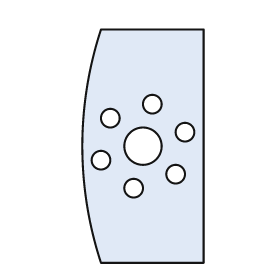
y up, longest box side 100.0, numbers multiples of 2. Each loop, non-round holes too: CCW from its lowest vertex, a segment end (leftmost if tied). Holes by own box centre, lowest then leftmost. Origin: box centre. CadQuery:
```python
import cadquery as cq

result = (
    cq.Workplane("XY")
    .moveTo(-18.0, -50.0)
    .lineTo(26.0, -50.0)
    .lineTo(26.0, 50.0)
    .lineTo(-18.0, 50.0)
    .threePointArc((-26.0, 0.0), (-18.0, -50.0))
    .close()
    .moveTo(-4.0, -18.0)
    .circle(4.0)
    .moveTo(14.0, -12.0)
    .circle(4.0)
    .moveTo(-18.0, -6.0)
    .circle(4.0)
    .moveTo(0.0, 0.0)
    .circle(8.0)
    .moveTo(18.0, 6.0)
    .circle(4.0)
    .moveTo(-14.0, 12.0)
    .circle(4.0)
    .moveTo(4.0, 18.0)
    .circle(4.0)
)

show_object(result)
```